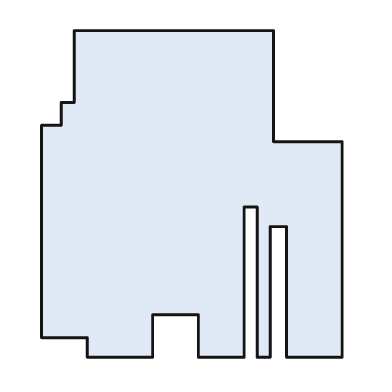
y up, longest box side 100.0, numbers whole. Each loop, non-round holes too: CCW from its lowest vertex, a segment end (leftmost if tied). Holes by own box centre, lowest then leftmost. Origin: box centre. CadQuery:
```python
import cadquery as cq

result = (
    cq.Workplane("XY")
    .moveTo(-32.0, -50.0)
    .lineTo(-12.0, -50.0)
    .lineTo(-12.0, -37.0)
    .lineTo(2.0, -37.0)
    .lineTo(2.0, -50.0)
    .lineTo(16.0, -50.0)
    .lineTo(16.0, -4.0)
    .lineTo(20.0, -4.0)
    .lineTo(20.0, -50.0)
    .lineTo(24.0, -50.0)
    .lineTo(24.0, -10.0)
    .lineTo(29.0, -10.0)
    .lineTo(29.0, -50.0)
    .lineTo(46.0, -50.0)
    .lineTo(46.0, 16.0)
    .lineTo(25.0, 16.0)
    .lineTo(25.0, 50.0)
    .lineTo(-36.0, 50.0)
    .lineTo(-36.0, 28.0)
    .lineTo(-40.0, 28.0)
    .lineTo(-40.0, 21.0)
    .lineTo(-46.0, 21.0)
    .lineTo(-46.0, -44.0)
    .lineTo(-32.0, -44.0)
    .close()
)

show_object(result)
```